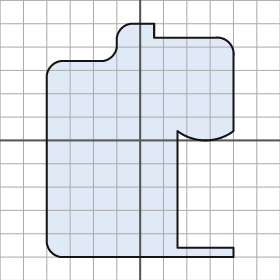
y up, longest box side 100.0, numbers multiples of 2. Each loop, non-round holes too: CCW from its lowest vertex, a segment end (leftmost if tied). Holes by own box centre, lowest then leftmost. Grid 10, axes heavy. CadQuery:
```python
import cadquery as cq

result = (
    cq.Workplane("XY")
    .moveTo(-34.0, -50.0)
    .lineTo(40.0, -50.0)
    .lineTo(40.0, -46.0)
    .lineTo(16.0, -46.0)
    .lineTo(16.0, 4.0)
    .threePointArc((28.0, 0.0), (40.0, 4.0))
    .lineTo(40.0, 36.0)
    .threePointArc((38.0, 42.0), (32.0, 44.0))
    .lineTo(6.0, 44.0)
    .lineTo(6.0, 50.0)
    .lineTo(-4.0, 50.0)
    .threePointArc((-8.0, 48.0), (-10.0, 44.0))
    .lineTo(-10.0, 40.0)
    .threePointArc((-12.0, 36.0), (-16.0, 34.0))
    .lineTo(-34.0, 34.0)
    .threePointArc((-38.0, 32.0), (-40.0, 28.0))
    .lineTo(-40.0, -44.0)
    .threePointArc((-38.0, -48.0), (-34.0, -50.0))
    .close()
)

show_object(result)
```